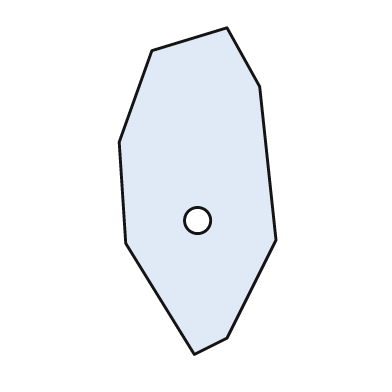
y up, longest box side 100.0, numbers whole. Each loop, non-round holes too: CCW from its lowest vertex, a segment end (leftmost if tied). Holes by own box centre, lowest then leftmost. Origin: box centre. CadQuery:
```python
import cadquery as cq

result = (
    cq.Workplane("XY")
    .moveTo(-1.0, -50.0)
    .lineTo(9.0, -45.0)
    .lineTo(24.0, -15.0)
    .lineTo(19.0, 32.0)
    .lineTo(9.0, 50.0)
    .lineTo(-14.0, 43.0)
    .lineTo(-24.0, 15.0)
    .lineTo(-22.0, -16.0)
    .close()
    .moveTo(0.0, -9.0)
    .circle(4.0)
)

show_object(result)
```